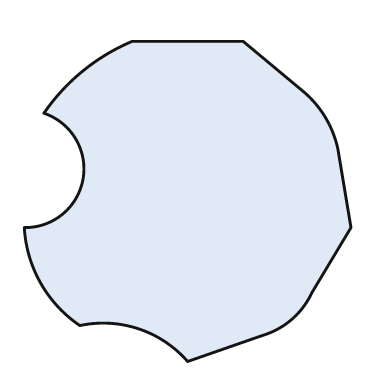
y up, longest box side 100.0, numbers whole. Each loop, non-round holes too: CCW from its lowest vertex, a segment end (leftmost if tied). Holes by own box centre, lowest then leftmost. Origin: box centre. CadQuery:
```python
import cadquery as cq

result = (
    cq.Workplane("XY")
    .moveTo(0.0, -49.0)
    .lineTo(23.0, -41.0)
    .threePointArc((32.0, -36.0), (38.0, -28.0))
    .lineTo(50.0, -8.0)
    .lineTo(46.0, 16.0)
    .threePointArc((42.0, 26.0), (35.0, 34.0))
    .lineTo(17.0, 49.0)
    .lineTo(-17.0, 49.0)
    .threePointArc((-32.0, 40.0), (-44.0, 27.0))
    .threePointArc((-32.0, 7.0), (-50.0, -8.0))
    .threePointArc((-45.0, -25.0), (-33.0, -38.0))
    .threePointArc((-15.0, -39.0), (0.0, -49.0))
    .close()
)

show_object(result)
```